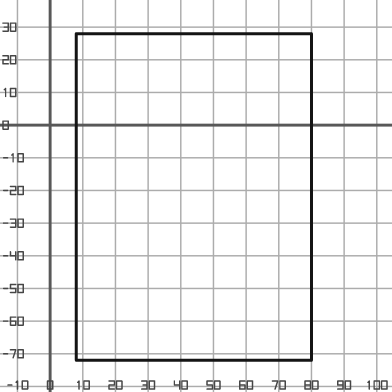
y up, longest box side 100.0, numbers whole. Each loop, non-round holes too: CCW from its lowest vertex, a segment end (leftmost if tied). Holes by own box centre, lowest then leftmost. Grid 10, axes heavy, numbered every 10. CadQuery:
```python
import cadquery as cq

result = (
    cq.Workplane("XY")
    .moveTo(8.0, -72.0)
    .lineTo(80.0, -72.0)
    .lineTo(80.0, 28.0)
    .lineTo(8.0, 28.0)
    .close()
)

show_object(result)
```